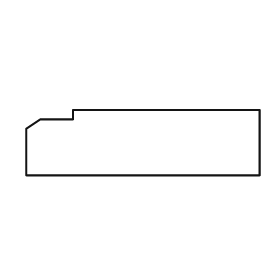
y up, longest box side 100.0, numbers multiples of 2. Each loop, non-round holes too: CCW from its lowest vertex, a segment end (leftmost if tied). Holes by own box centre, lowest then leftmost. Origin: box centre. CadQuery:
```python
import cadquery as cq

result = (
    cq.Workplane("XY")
    .moveTo(-50.0, -14.0)
    .lineTo(50.0, -14.0)
    .lineTo(50.0, 14.0)
    .lineTo(-30.0, 14.0)
    .lineTo(-30.0, 10.0)
    .lineTo(-44.0, 10.0)
    .lineTo(-50.0, 6.0)
    .close()
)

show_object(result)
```